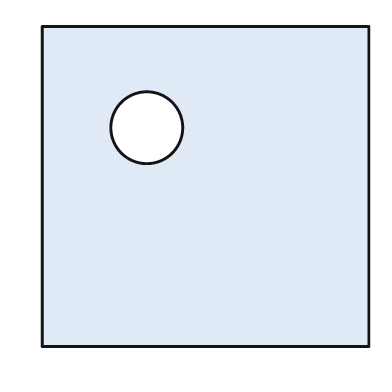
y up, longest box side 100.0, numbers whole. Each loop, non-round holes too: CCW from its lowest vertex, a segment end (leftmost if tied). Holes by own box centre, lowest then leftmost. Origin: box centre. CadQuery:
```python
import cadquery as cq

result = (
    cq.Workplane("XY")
    .moveTo(-50.0, -49.0)
    .lineTo(50.0, -49.0)
    .lineTo(50.0, 49.0)
    .lineTo(-50.0, 49.0)
    .close()
    .moveTo(-18.0, 18.0)
    .circle(11.0)
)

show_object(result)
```